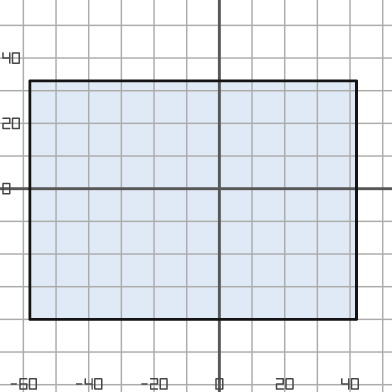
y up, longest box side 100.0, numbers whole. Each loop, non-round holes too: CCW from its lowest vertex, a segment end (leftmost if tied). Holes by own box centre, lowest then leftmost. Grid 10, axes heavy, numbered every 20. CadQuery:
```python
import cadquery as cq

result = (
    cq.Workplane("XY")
    .moveTo(-58.0, -40.0)
    .lineTo(42.0, -40.0)
    .lineTo(42.0, 33.0)
    .lineTo(-58.0, 33.0)
    .close()
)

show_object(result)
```